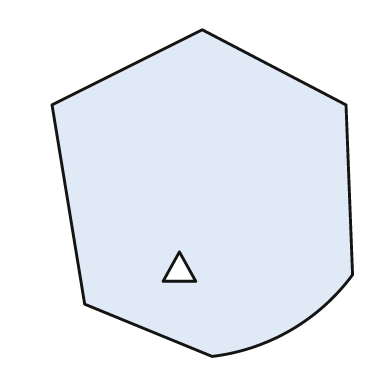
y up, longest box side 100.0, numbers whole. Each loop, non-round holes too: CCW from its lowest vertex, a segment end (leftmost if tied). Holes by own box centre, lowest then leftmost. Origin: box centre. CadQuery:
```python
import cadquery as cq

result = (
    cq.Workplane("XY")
    .moveTo(3.0, -50.0)
    .threePointArc((27.0, -42.0), (46.0, -25.0))
    .lineTo(44.0, 27.0)
    .lineTo(0.0, 50.0)
    .lineTo(-46.0, 27.0)
    .lineTo(-36.0, -34.0)
    .close()
    .moveTo(-12.0, -27.0)
    .lineTo(-2.0, -27.0)
    .lineTo(-7.0, -18.0)
    .close()
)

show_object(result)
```